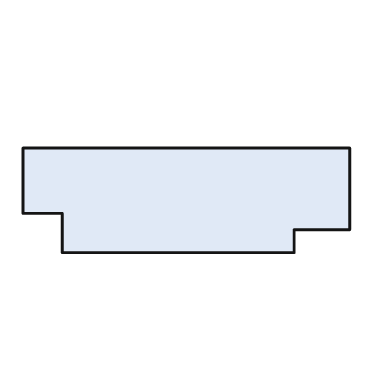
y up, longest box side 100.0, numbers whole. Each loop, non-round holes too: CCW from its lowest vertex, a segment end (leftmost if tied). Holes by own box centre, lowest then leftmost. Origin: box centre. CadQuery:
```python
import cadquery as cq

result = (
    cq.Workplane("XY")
    .moveTo(-38.0, -16.0)
    .lineTo(33.0, -16.0)
    .lineTo(33.0, -9.0)
    .lineTo(50.0, -9.0)
    .lineTo(50.0, 16.0)
    .lineTo(-50.0, 16.0)
    .lineTo(-50.0, -4.0)
    .lineTo(-38.0, -4.0)
    .close()
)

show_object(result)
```